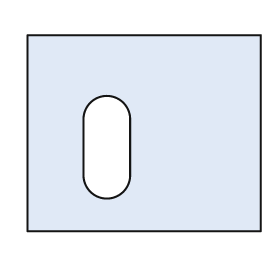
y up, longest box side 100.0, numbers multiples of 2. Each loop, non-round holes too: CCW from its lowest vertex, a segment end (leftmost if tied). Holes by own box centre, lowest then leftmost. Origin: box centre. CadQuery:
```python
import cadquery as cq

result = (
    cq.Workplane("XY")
    .moveTo(-50.0, -42.0)
    .lineTo(50.0, -42.0)
    .lineTo(50.0, 42.0)
    .lineTo(-50.0, 42.0)
    .close()
    .moveTo(-26.0, -18.0)
    .threePointArc((-16.0, -28.0), (-6.0, -18.0))
    .lineTo(-6.0, 6.0)
    .threePointArc((-16.0, 16.0), (-26.0, 6.0))
    .close()
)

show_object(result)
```